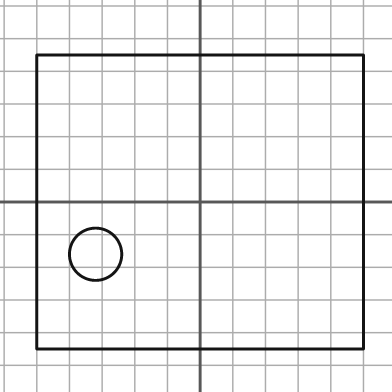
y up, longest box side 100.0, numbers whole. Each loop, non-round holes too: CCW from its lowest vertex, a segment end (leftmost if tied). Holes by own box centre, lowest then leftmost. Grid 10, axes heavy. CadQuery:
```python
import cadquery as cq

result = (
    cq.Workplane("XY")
    .moveTo(-50.0, -45.0)
    .lineTo(50.0, -45.0)
    .lineTo(50.0, 45.0)
    .lineTo(-50.0, 45.0)
    .close()
    .moveTo(-32.0, -16.0)
    .circle(8.0)
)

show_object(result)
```